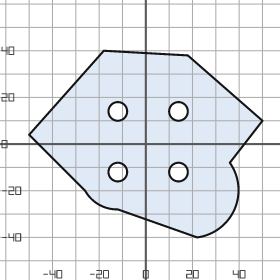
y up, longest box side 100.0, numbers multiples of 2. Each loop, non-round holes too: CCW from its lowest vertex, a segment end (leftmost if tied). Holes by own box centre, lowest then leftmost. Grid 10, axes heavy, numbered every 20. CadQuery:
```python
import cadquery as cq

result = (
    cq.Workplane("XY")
    .moveTo(22.0, -40.0)
    .threePointArc((38.0, -28.0), (36.0, -8.0))
    .lineTo(50.0, 10.0)
    .lineTo(18.0, 38.0)
    .lineTo(-18.0, 40.0)
    .lineTo(-50.0, 4.0)
    .lineTo(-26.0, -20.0)
    .threePointArc((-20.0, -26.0), (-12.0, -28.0))
    .close()
    .moveTo(-12.0, -12.0)
    .circle(4.0)
    .moveTo(14.0, -12.0)
    .circle(4.0)
    .moveTo(-12.0, 14.0)
    .circle(4.0)
    .moveTo(14.0, 14.0)
    .circle(4.0)
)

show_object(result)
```